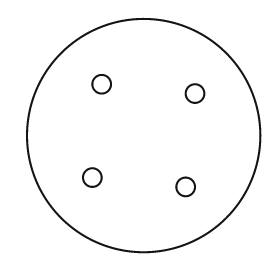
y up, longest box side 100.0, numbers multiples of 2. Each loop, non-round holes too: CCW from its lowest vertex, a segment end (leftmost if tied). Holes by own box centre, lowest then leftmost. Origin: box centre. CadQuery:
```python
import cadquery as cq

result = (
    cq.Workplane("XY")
    .moveTo(0.0, 0.0)
    .circle(50.0)
    .moveTo(18.0, -22.0)
    .circle(4.0)
    .moveTo(-22.0, -18.0)
    .circle(4.0)
    .moveTo(22.0, 18.0)
    .circle(4.0)
    .moveTo(-18.0, 22.0)
    .circle(4.0)
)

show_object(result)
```